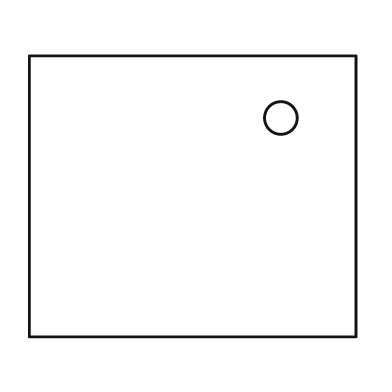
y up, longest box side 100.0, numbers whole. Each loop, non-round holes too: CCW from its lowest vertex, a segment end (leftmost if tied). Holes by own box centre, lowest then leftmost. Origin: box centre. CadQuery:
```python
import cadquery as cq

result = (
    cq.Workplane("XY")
    .moveTo(-50.0, -43.0)
    .lineTo(50.0, -43.0)
    .lineTo(50.0, 43.0)
    .lineTo(-50.0, 43.0)
    .close()
    .moveTo(27.0, 24.0)
    .circle(5.0)
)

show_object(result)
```